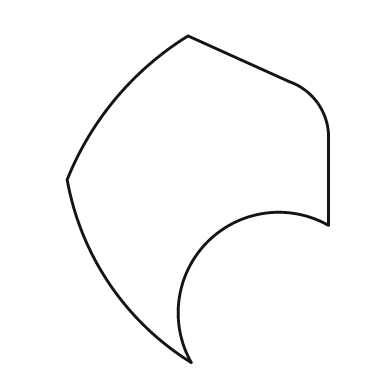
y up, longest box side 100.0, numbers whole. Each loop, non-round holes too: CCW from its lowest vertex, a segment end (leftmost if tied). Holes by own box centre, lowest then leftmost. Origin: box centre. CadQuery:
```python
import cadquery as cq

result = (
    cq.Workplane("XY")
    .moveTo(-2.0, -50.0)
    .threePointArc((3.0, -13.0), (40.0, -8.0))
    .lineTo(40.0, 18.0)
    .threePointArc((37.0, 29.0), (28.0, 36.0))
    .lineTo(-3.0, 50.0)
    .threePointArc((-25.0, 31.0), (-40.0, 6.0))
    .threePointArc((-27.0, -26.0), (-2.0, -50.0))
    .close()
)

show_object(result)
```